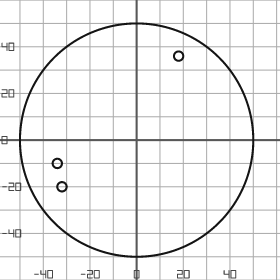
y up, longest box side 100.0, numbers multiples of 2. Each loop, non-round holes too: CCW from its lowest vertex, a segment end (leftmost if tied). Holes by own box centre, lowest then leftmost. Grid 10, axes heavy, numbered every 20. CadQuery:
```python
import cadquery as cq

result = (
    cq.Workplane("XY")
    .moveTo(0.0, 0.0)
    .circle(50.0)
    .moveTo(-32.0, -20.0)
    .circle(2.0)
    .moveTo(-34.0, -10.0)
    .circle(2.0)
    .moveTo(18.0, 36.0)
    .circle(2.0)
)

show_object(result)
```